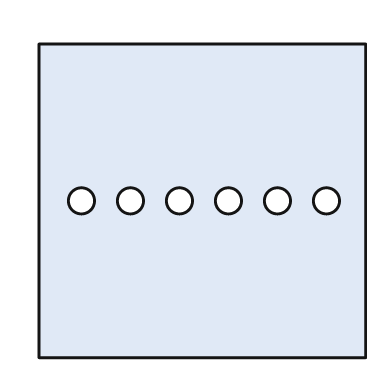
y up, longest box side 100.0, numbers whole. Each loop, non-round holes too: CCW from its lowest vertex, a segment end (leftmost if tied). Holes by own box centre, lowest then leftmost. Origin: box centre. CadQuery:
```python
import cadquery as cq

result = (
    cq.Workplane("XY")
    .moveTo(-50.0, -48.0)
    .lineTo(50.0, -48.0)
    .lineTo(50.0, 48.0)
    .lineTo(-50.0, 48.0)
    .close()
    .moveTo(-37.0, 0.0)
    .circle(4.0)
    .moveTo(-22.0, 0.0)
    .circle(4.0)
    .moveTo(-7.0, 0.0)
    .circle(4.0)
    .moveTo(8.0, 0.0)
    .circle(4.0)
    .moveTo(23.0, 0.0)
    .circle(4.0)
    .moveTo(38.0, 0.0)
    .circle(4.0)
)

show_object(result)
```